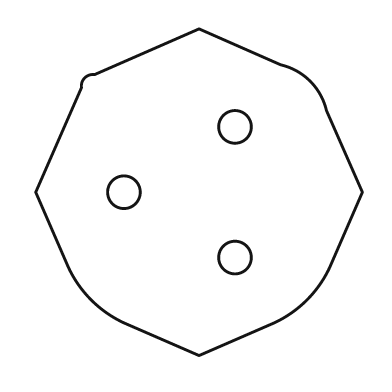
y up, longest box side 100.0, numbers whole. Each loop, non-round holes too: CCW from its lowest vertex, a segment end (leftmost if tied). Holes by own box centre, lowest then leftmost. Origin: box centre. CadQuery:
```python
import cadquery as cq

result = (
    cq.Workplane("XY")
    .moveTo(0.0, -50.0)
    .lineTo(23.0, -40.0)
    .threePointArc((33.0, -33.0), (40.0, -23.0))
    .lineTo(50.0, 0.0)
    .lineTo(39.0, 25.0)
    .threePointArc((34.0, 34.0), (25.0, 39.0))
    .lineTo(0.0, 50.0)
    .lineTo(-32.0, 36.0)
    .threePointArc((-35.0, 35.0), (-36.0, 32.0))
    .lineTo(-50.0, 0.0)
    .lineTo(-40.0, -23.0)
    .threePointArc((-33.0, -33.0), (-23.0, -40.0))
    .close()
    .moveTo(11.0, -20.0)
    .circle(5.0)
    .moveTo(-23.0, 0.0)
    .circle(5.0)
    .moveTo(11.0, 20.0)
    .circle(5.0)
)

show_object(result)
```